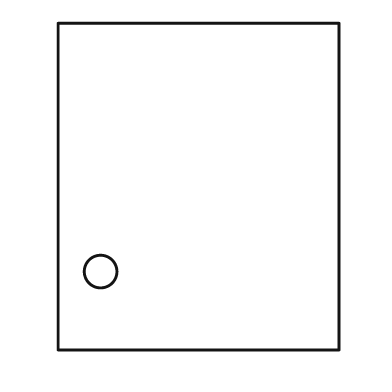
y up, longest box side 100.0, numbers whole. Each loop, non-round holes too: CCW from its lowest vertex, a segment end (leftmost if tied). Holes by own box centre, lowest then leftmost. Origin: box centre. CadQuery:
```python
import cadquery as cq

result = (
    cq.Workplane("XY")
    .moveTo(-43.0, -50.0)
    .lineTo(43.0, -50.0)
    .lineTo(43.0, 50.0)
    .lineTo(-43.0, 50.0)
    .close()
    .moveTo(-30.0, -26.0)
    .circle(5.0)
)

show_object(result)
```